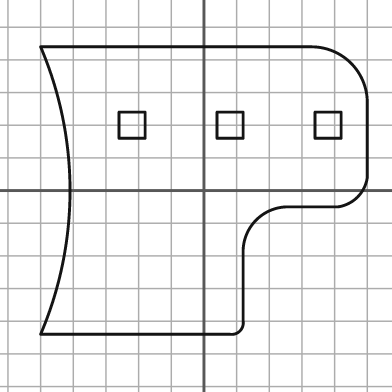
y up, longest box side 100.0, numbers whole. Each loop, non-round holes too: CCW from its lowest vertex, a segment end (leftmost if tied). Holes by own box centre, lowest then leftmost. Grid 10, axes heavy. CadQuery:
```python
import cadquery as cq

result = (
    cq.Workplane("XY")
    .moveTo(-50.0, -44.0)
    .lineTo(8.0, -44.0)
    .threePointArc((11.0, -43.0), (12.0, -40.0))
    .lineTo(12.0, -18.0)
    .threePointArc((16.0, -9.0), (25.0, -5.0))
    .lineTo(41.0, -5.0)
    .threePointArc((47.0, -2.0), (50.0, 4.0))
    .lineTo(50.0, 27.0)
    .threePointArc((45.0, 39.0), (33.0, 44.0))
    .lineTo(-50.0, 44.0)
    .threePointArc((-41.0, 0.0), (-50.0, -44.0))
    .close()
    .moveTo(-26.0, 16.0)
    .lineTo(-18.0, 16.0)
    .lineTo(-18.0, 24.0)
    .lineTo(-26.0, 24.0)
    .close()
    .moveTo(4.0, 16.0)
    .lineTo(12.0, 16.0)
    .lineTo(12.0, 24.0)
    .lineTo(4.0, 24.0)
    .close()
    .moveTo(34.0, 16.0)
    .lineTo(42.0, 16.0)
    .lineTo(42.0, 24.0)
    .lineTo(34.0, 24.0)
    .close()
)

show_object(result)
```